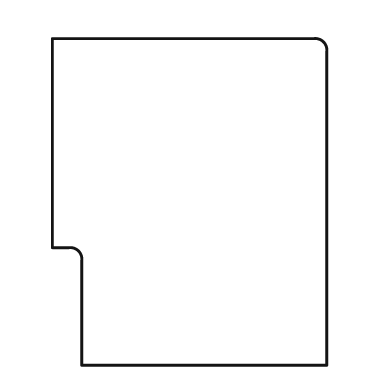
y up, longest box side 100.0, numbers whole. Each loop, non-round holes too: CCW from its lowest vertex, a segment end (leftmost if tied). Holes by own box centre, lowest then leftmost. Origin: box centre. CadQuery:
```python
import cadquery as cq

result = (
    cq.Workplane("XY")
    .moveTo(-33.0, -50.0)
    .lineTo(42.0, -50.0)
    .lineTo(42.0, 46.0)
    .threePointArc((41.0, 49.0), (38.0, 50.0))
    .lineTo(-42.0, 50.0)
    .lineTo(-42.0, -14.0)
    .lineTo(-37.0, -14.0)
    .threePointArc((-34.0, -15.0), (-33.0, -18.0))
    .close()
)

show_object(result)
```